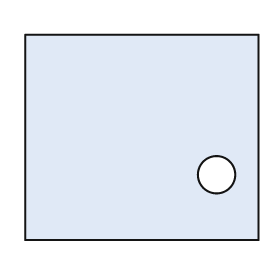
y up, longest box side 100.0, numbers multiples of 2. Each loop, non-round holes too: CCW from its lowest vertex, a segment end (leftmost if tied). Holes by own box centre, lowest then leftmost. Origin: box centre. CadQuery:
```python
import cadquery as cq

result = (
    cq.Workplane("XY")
    .moveTo(-50.0, -44.0)
    .lineTo(50.0, -44.0)
    .lineTo(50.0, 44.0)
    .lineTo(-50.0, 44.0)
    .close()
    .moveTo(32.0, -16.0)
    .circle(8.0)
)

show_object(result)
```